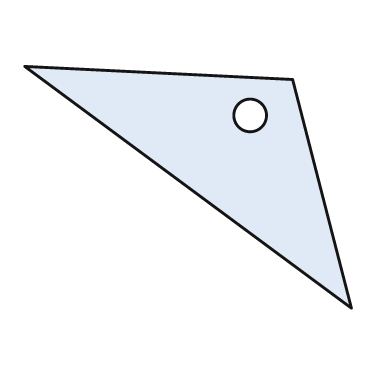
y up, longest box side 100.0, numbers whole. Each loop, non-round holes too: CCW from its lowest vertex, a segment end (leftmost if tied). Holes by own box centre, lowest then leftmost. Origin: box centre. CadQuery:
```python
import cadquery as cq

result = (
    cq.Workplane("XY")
    .moveTo(50.0, -37.0)
    .lineTo(32.0, 33.0)
    .lineTo(-50.0, 37.0)
    .close()
    .moveTo(19.0, 22.0)
    .circle(5.0)
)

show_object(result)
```